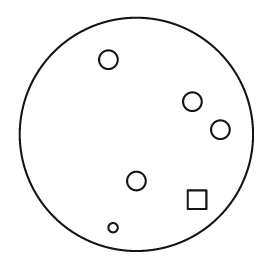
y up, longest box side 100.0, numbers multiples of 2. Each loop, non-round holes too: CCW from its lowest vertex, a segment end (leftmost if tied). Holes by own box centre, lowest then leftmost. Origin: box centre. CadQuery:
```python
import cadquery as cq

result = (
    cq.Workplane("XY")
    .moveTo(0.0, 0.0)
    .circle(50.0)
    .moveTo(-10.0, -40.0)
    .circle(2.0)
    .moveTo(22.0, -32.0)
    .lineTo(30.0, -32.0)
    .lineTo(30.0, -24.0)
    .lineTo(22.0, -24.0)
    .close()
    .moveTo(0.0, -20.0)
    .circle(4.0)
    .moveTo(36.0, 2.0)
    .circle(4.0)
    .moveTo(24.0, 14.0)
    .circle(4.0)
    .moveTo(-12.0, 32.0)
    .circle(4.0)
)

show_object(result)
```